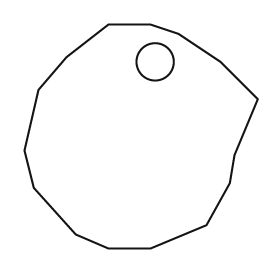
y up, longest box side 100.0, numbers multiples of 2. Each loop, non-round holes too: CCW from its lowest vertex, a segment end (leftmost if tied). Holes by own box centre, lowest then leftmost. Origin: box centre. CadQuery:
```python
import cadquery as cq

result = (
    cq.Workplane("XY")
    .moveTo(-14.0, -48.0)
    .lineTo(4.0, -48.0)
    .lineTo(28.0, -38.0)
    .lineTo(38.0, -20.0)
    .lineTo(40.0, -8.0)
    .lineTo(50.0, 16.0)
    .lineTo(34.0, 32.0)
    .lineTo(16.0, 44.0)
    .lineTo(4.0, 48.0)
    .lineTo(-14.0, 48.0)
    .lineTo(-32.0, 34.0)
    .lineTo(-44.0, 20.0)
    .lineTo(-50.0, -6.0)
    .lineTo(-46.0, -22.0)
    .lineTo(-28.0, -42.0)
    .close()
    .moveTo(6.0, 32.0)
    .circle(8.0)
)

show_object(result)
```